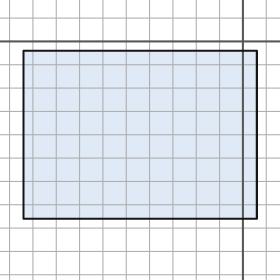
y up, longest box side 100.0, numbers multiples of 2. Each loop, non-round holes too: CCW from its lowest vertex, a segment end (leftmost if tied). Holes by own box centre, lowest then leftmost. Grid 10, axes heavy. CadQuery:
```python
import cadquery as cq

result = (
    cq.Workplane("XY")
    .moveTo(-94.0, -76.0)
    .lineTo(6.0, -76.0)
    .lineTo(6.0, -4.0)
    .lineTo(-94.0, -4.0)
    .close()
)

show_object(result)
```